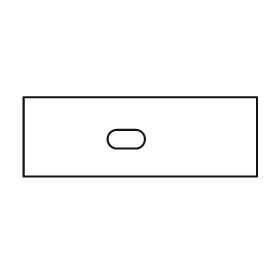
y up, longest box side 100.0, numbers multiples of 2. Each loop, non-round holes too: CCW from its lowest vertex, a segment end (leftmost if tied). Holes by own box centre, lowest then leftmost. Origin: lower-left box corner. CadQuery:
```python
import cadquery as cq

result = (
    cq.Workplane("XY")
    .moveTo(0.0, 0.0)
    .lineTo(100.0, 0.0)
    .lineTo(100.0, 34.0)
    .lineTo(0.0, 34.0)
    .close()
    .moveTo(40.0, 12.0)
    .lineTo(48.0, 12.0)
    .threePointArc((52.0, 16.0), (48.0, 20.0))
    .lineTo(40.0, 20.0)
    .threePointArc((36.0, 16.0), (40.0, 12.0))
    .close()
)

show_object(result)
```